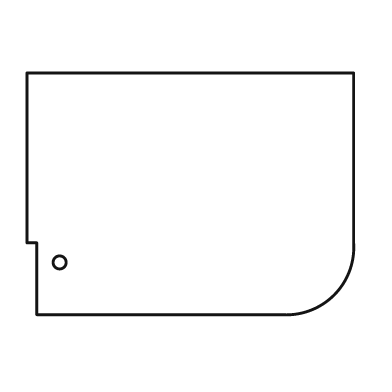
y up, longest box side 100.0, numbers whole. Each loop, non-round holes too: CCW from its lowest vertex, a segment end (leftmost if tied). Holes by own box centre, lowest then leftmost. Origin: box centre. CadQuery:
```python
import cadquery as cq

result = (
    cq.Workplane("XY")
    .moveTo(-47.0, -37.0)
    .lineTo(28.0, -37.0)
    .threePointArc((44.0, -31.0), (50.0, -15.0))
    .lineTo(50.0, 37.0)
    .lineTo(-50.0, 37.0)
    .lineTo(-50.0, -15.0)
    .lineTo(-47.0, -15.0)
    .close()
    .moveTo(-40.0, -21.0)
    .circle(2.0)
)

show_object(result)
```